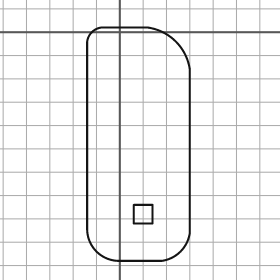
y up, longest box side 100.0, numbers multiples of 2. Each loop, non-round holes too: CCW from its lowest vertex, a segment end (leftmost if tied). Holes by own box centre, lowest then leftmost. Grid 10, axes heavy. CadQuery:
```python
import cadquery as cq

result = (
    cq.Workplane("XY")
    .moveTo(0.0, -98.0)
    .lineTo(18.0, -98.0)
    .threePointArc((26.0, -94.0), (30.0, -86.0))
    .lineTo(30.0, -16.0)
    .threePointArc((24.0, -4.0), (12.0, 2.0))
    .lineTo(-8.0, 2.0)
    .threePointArc((-12.0, 0.0), (-14.0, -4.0))
    .lineTo(-14.0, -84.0)
    .threePointArc((-10.0, -94.0), (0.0, -98.0))
    .close()
    .moveTo(6.0, -82.0)
    .lineTo(14.0, -82.0)
    .lineTo(14.0, -74.0)
    .lineTo(6.0, -74.0)
    .close()
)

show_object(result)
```